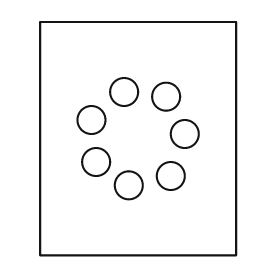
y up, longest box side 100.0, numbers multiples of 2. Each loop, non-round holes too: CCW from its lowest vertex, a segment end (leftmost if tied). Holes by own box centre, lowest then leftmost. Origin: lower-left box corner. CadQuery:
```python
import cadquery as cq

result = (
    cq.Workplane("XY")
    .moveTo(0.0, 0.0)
    .lineTo(84.0, 0.0)
    .lineTo(84.0, 100.0)
    .lineTo(0.0, 100.0)
    .close()
    .moveTo(38.0, 30.0)
    .circle(6.0)
    .moveTo(56.0, 34.0)
    .circle(6.0)
    .moveTo(24.0, 40.0)
    .circle(6.0)
    .moveTo(62.0, 52.0)
    .circle(6.0)
    .moveTo(22.0, 58.0)
    .circle(6.0)
    .moveTo(54.0, 68.0)
    .circle(6.0)
    .moveTo(36.0, 70.0)
    .circle(6.0)
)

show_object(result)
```